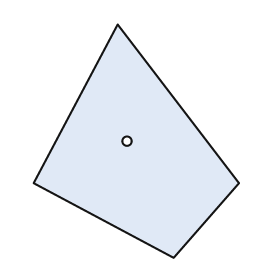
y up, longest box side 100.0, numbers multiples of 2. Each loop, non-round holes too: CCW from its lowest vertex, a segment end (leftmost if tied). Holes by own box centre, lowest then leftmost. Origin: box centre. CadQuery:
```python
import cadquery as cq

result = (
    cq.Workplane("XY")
    .moveTo(16.0, -50.0)
    .lineTo(44.0, -18.0)
    .lineTo(-8.0, 50.0)
    .lineTo(-44.0, -18.0)
    .close()
    .moveTo(-4.0, 0.0)
    .circle(2.0)
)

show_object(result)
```